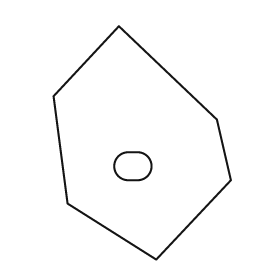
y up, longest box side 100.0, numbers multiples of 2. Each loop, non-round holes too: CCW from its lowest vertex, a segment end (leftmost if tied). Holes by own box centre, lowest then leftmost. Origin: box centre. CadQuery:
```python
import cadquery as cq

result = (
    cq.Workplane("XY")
    .moveTo(6.0, -50.0)
    .lineTo(38.0, -16.0)
    .lineTo(32.0, 10.0)
    .lineTo(-10.0, 50.0)
    .lineTo(-38.0, 20.0)
    .lineTo(-32.0, -26.0)
    .close()
    .moveTo(-6.0, -16.0)
    .lineTo(-2.0, -16.0)
    .threePointArc((4.0, -10.0), (-2.0, -4.0))
    .lineTo(-6.0, -4.0)
    .threePointArc((-12.0, -10.0), (-6.0, -16.0))
    .close()
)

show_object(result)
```